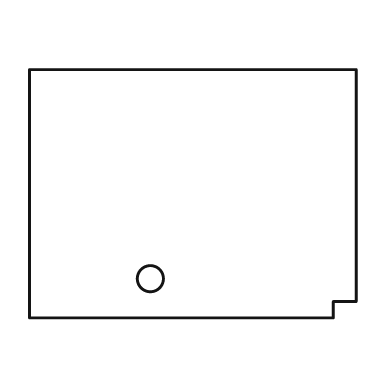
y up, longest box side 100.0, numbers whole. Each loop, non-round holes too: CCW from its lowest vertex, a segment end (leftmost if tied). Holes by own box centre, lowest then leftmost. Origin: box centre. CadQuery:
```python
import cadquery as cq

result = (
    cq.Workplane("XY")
    .moveTo(-50.0, -38.0)
    .lineTo(43.0, -38.0)
    .lineTo(43.0, -33.0)
    .lineTo(50.0, -33.0)
    .lineTo(50.0, 38.0)
    .lineTo(-50.0, 38.0)
    .close()
    .moveTo(-13.0, -26.0)
    .circle(4.0)
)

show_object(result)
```